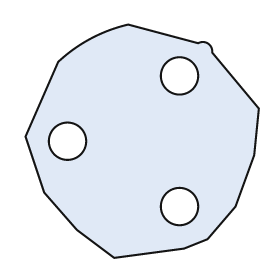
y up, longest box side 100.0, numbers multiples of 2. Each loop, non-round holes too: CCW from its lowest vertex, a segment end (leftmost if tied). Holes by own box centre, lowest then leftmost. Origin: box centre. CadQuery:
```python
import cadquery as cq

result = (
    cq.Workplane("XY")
    .moveTo(-12.0, -50.0)
    .lineTo(18.0, -46.0)
    .lineTo(28.0, -42.0)
    .lineTo(40.0, -28.0)
    .lineTo(48.0, -6.0)
    .lineTo(50.0, 14.0)
    .lineTo(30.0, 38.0)
    .threePointArc((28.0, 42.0), (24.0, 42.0))
    .lineTo(-6.0, 50.0)
    .threePointArc((-22.0, 44.0), (-36.0, 34.0))
    .lineTo(-50.0, 2.0)
    .lineTo(-42.0, -22.0)
    .lineTo(-28.0, -38.0)
    .close()
    .moveTo(16.0, -28.0)
    .circle(8.0)
    .moveTo(-32.0, 0.0)
    .circle(8.0)
    .moveTo(16.0, 28.0)
    .circle(8.0)
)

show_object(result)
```